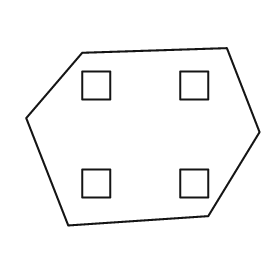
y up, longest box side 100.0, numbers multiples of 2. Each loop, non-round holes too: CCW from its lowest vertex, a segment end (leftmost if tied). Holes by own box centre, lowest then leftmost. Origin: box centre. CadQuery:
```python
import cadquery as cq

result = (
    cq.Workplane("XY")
    .moveTo(-32.0, -38.0)
    .lineTo(28.0, -34.0)
    .lineTo(50.0, 2.0)
    .lineTo(36.0, 38.0)
    .lineTo(-26.0, 36.0)
    .lineTo(-50.0, 8.0)
    .close()
    .moveTo(-26.0, -26.0)
    .lineTo(-14.0, -26.0)
    .lineTo(-14.0, -14.0)
    .lineTo(-26.0, -14.0)
    .close()
    .moveTo(16.0, -26.0)
    .lineTo(28.0, -26.0)
    .lineTo(28.0, -14.0)
    .lineTo(16.0, -14.0)
    .close()
    .moveTo(-26.0, 16.0)
    .lineTo(-14.0, 16.0)
    .lineTo(-14.0, 28.0)
    .lineTo(-26.0, 28.0)
    .close()
    .moveTo(16.0, 16.0)
    .lineTo(28.0, 16.0)
    .lineTo(28.0, 28.0)
    .lineTo(16.0, 28.0)
    .close()
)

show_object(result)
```